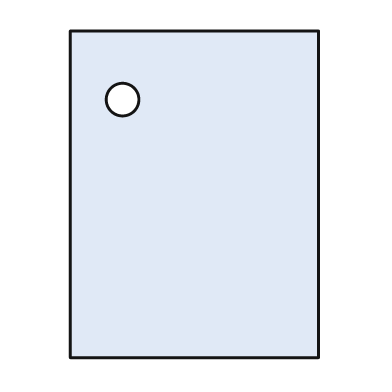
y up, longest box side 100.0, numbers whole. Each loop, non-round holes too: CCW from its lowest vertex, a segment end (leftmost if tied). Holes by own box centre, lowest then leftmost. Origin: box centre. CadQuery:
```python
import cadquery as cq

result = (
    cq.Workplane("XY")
    .moveTo(-38.0, -50.0)
    .lineTo(38.0, -50.0)
    .lineTo(38.0, 50.0)
    .lineTo(-38.0, 50.0)
    .close()
    .moveTo(-22.0, 29.0)
    .circle(5.0)
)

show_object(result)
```